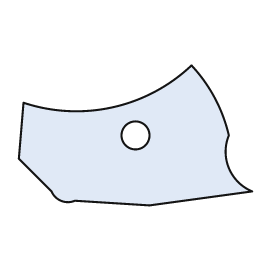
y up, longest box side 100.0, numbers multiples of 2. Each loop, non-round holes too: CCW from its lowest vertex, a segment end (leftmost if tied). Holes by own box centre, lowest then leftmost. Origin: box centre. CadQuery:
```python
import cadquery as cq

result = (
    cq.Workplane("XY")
    .moveTo(6.0, -30.0)
    .lineTo(50.0, -24.0)
    .threePointArc((40.0, -14.0), (40.0, 0.0))
    .threePointArc((34.0, 16.0), (24.0, 30.0))
    .threePointArc((-10.0, 12.0), (-48.0, 14.0))
    .lineTo(-50.0, -10.0)
    .lineTo(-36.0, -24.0)
    .threePointArc((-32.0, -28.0), (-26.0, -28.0))
    .close()
    .moveTo(0.0, 0.0)
    .circle(6.0)
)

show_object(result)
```